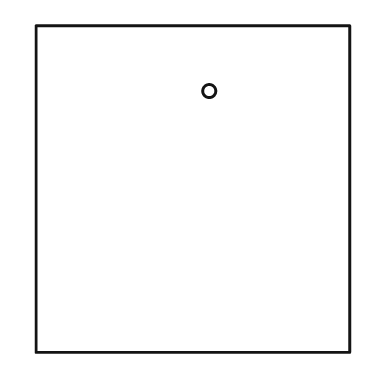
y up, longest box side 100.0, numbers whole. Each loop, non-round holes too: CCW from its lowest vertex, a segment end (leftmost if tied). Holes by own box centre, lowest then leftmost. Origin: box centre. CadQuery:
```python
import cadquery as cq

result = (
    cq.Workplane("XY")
    .moveTo(-48.0, -50.0)
    .lineTo(48.0, -50.0)
    .lineTo(48.0, 50.0)
    .lineTo(-48.0, 50.0)
    .close()
    .moveTo(5.0, 30.0)
    .circle(2.0)
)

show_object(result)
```